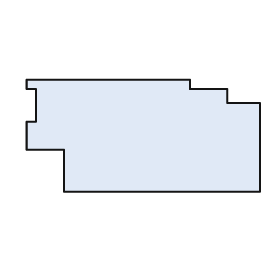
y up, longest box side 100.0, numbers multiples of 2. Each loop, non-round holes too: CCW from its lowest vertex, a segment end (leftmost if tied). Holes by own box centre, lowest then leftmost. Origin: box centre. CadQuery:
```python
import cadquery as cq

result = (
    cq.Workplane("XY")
    .moveTo(-34.0, -24.0)
    .lineTo(50.0, -24.0)
    .lineTo(50.0, 14.0)
    .lineTo(36.0, 14.0)
    .lineTo(36.0, 20.0)
    .lineTo(20.0, 20.0)
    .lineTo(20.0, 24.0)
    .lineTo(-50.0, 24.0)
    .lineTo(-50.0, 20.0)
    .lineTo(-46.0, 20.0)
    .lineTo(-46.0, 6.0)
    .lineTo(-50.0, 6.0)
    .lineTo(-50.0, -6.0)
    .lineTo(-34.0, -6.0)
    .close()
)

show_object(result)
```